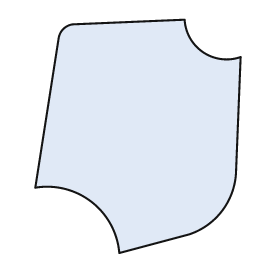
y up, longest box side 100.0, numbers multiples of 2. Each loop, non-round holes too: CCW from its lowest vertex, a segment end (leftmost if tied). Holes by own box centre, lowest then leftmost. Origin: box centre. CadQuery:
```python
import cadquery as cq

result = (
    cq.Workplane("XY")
    .moveTo(-8.0, -50.0)
    .lineTo(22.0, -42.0)
    .threePointArc((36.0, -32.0), (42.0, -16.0))
    .lineTo(44.0, 34.0)
    .threePointArc((28.0, 36.0), (20.0, 50.0))
    .lineTo(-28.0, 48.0)
    .threePointArc((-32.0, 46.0), (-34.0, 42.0))
    .lineTo(-44.0, -22.0)
    .threePointArc((-20.0, -28.0), (-8.0, -50.0))
    .close()
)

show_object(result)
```